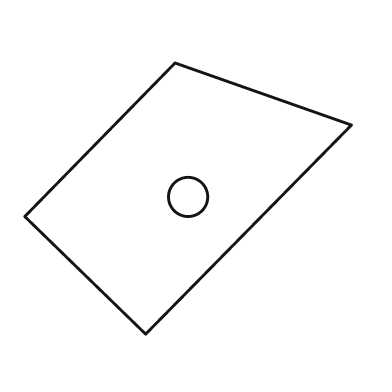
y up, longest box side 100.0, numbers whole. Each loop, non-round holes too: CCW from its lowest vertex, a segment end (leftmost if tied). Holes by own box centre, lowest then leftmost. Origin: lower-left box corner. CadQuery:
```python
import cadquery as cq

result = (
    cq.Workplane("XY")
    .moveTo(37.0, 0.0)
    .lineTo(100.0, 64.0)
    .lineTo(46.0, 83.0)
    .lineTo(0.0, 36.0)
    .close()
    .moveTo(50.0, 42.0)
    .circle(6.0)
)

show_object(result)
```